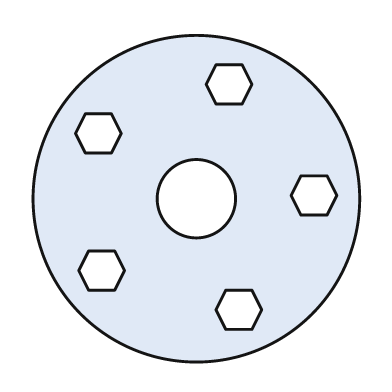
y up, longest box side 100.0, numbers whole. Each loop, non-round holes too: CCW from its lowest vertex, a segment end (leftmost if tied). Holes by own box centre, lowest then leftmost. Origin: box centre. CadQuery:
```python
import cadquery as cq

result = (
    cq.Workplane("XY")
    .moveTo(0.0, 0.0)
    .circle(50.0)
    .moveTo(9.0, -40.0)
    .lineTo(17.0, -40.0)
    .lineTo(20.0, -34.0)
    .lineTo(17.0, -28.0)
    .lineTo(9.0, -28.0)
    .lineTo(6.0, -34.0)
    .close()
    .moveTo(-33.0, -28.0)
    .lineTo(-25.0, -28.0)
    .lineTo(-22.0, -22.0)
    .lineTo(-25.0, -16.0)
    .lineTo(-33.0, -16.0)
    .lineTo(-36.0, -22.0)
    .close()
    .moveTo(0.0, 0.0)
    .circle(12.0)
    .moveTo(32.0, -5.0)
    .lineTo(40.0, -5.0)
    .lineTo(43.0, 1.0)
    .lineTo(40.0, 7.0)
    .lineTo(32.0, 7.0)
    .lineTo(29.0, 1.0)
    .close()
    .moveTo(-34.0, 14.0)
    .lineTo(-26.0, 14.0)
    .lineTo(-23.0, 20.0)
    .lineTo(-26.0, 26.0)
    .lineTo(-34.0, 26.0)
    .lineTo(-37.0, 20.0)
    .close()
    .moveTo(6.0, 29.0)
    .lineTo(14.0, 29.0)
    .lineTo(17.0, 35.0)
    .lineTo(14.0, 41.0)
    .lineTo(6.0, 41.0)
    .lineTo(3.0, 35.0)
    .close()
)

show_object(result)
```